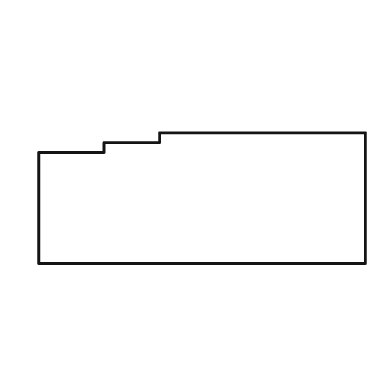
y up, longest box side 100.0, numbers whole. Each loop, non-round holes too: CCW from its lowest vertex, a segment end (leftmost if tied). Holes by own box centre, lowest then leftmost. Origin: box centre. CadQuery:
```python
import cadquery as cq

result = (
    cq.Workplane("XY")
    .moveTo(-50.0, -20.0)
    .lineTo(50.0, -20.0)
    .lineTo(50.0, 20.0)
    .lineTo(-13.0, 20.0)
    .lineTo(-13.0, 17.0)
    .lineTo(-30.0, 17.0)
    .lineTo(-30.0, 14.0)
    .lineTo(-50.0, 14.0)
    .close()
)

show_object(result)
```